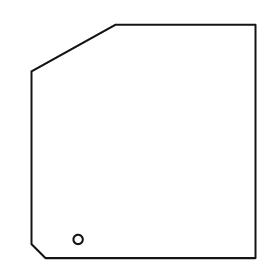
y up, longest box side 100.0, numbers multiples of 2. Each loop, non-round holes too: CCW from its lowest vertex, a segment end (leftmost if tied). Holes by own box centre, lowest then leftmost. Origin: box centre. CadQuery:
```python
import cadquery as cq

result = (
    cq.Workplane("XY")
    .moveTo(-42.0, -50.0)
    .lineTo(48.0, -50.0)
    .lineTo(48.0, 50.0)
    .lineTo(-12.0, 50.0)
    .lineTo(-48.0, 30.0)
    .lineTo(-48.0, -44.0)
    .close()
    .moveTo(-28.0, -42.0)
    .circle(2.0)
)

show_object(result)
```